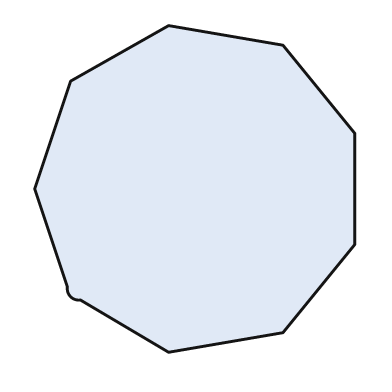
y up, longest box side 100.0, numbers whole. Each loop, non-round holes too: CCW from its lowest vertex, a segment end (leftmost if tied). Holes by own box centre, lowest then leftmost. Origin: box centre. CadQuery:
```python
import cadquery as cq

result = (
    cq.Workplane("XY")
    .moveTo(-8.0, -50.0)
    .lineTo(27.0, -44.0)
    .lineTo(49.0, -17.0)
    .lineTo(49.0, 17.0)
    .lineTo(27.0, 44.0)
    .lineTo(-8.0, 50.0)
    .lineTo(-38.0, 33.0)
    .lineTo(-49.0, 0.0)
    .lineTo(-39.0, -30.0)
    .threePointArc((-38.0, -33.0), (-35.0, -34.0))
    .close()
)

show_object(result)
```